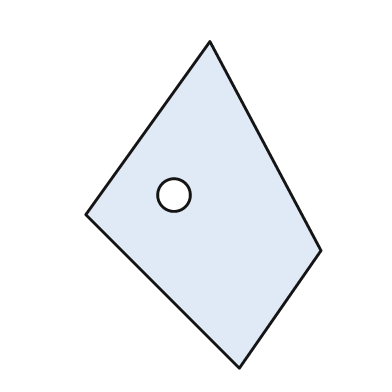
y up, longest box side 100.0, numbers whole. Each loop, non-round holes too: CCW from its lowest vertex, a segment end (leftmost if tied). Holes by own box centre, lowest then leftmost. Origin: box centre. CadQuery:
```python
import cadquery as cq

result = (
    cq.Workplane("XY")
    .moveTo(11.0, -50.0)
    .lineTo(36.0, -14.0)
    .lineTo(2.0, 50.0)
    .lineTo(-36.0, -3.0)
    .close()
    .moveTo(-9.0, 3.0)
    .circle(5.0)
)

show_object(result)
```